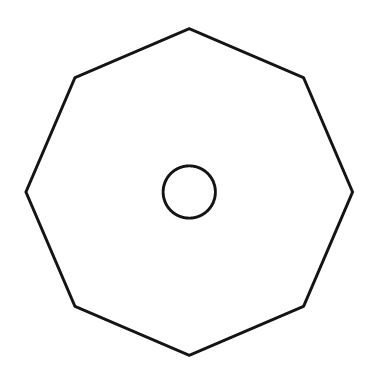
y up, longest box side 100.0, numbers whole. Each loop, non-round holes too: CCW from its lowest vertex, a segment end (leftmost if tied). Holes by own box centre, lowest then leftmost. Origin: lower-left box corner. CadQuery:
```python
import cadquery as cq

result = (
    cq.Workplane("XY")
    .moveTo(50.0, 0.0)
    .lineTo(85.0, 15.0)
    .lineTo(100.0, 50.0)
    .lineTo(85.0, 85.0)
    .lineTo(50.0, 100.0)
    .lineTo(15.0, 85.0)
    .lineTo(0.0, 50.0)
    .lineTo(15.0, 15.0)
    .close()
    .moveTo(50.0, 50.0)
    .circle(8.0)
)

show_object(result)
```